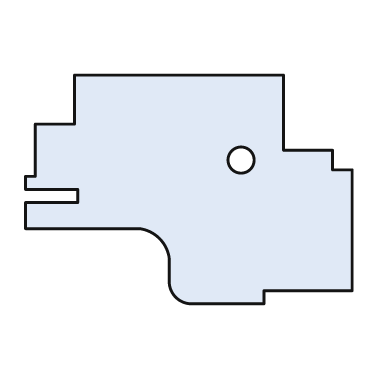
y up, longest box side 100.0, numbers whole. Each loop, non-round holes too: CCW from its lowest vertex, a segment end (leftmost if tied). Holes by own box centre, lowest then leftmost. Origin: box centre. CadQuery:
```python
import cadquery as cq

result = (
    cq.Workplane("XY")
    .moveTo(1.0, -35.0)
    .lineTo(23.0, -35.0)
    .lineTo(23.0, -31.0)
    .lineTo(50.0, -31.0)
    .lineTo(50.0, 6.0)
    .lineTo(44.0, 6.0)
    .lineTo(44.0, 12.0)
    .lineTo(29.0, 12.0)
    .lineTo(29.0, 35.0)
    .lineTo(-35.0, 35.0)
    .lineTo(-35.0, 20.0)
    .lineTo(-47.0, 20.0)
    .lineTo(-47.0, 4.0)
    .lineTo(-50.0, 4.0)
    .lineTo(-50.0, 0.0)
    .lineTo(-34.0, 0.0)
    .lineTo(-34.0, -4.0)
    .lineTo(-50.0, -4.0)
    .lineTo(-50.0, -12.0)
    .lineTo(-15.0, -12.0)
    .threePointArc((-9.0, -15.0), (-6.0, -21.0))
    .lineTo(-6.0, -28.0)
    .threePointArc((-4.0, -33.0), (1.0, -35.0))
    .close()
    .moveTo(16.0, 9.0)
    .circle(4.0)
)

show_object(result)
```